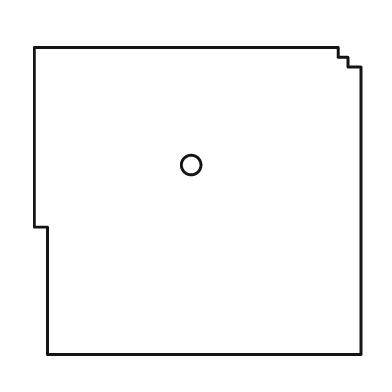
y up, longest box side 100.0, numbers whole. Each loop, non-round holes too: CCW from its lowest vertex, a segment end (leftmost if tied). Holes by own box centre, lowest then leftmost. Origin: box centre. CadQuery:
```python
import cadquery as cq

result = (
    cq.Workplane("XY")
    .moveTo(-46.0, -47.0)
    .lineTo(50.0, -47.0)
    .lineTo(50.0, 41.0)
    .lineTo(46.0, 41.0)
    .lineTo(46.0, 44.0)
    .lineTo(43.0, 44.0)
    .lineTo(43.0, 47.0)
    .lineTo(-50.0, 47.0)
    .lineTo(-50.0, -8.0)
    .lineTo(-46.0, -8.0)
    .close()
    .moveTo(-2.0, 11.0)
    .circle(3.0)
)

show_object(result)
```